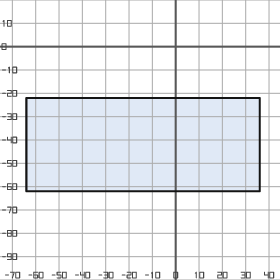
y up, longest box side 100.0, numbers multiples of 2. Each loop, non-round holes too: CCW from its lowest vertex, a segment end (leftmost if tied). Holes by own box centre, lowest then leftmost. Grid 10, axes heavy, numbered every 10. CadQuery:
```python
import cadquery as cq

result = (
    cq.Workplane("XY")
    .moveTo(-64.0, -62.0)
    .lineTo(36.0, -62.0)
    .lineTo(36.0, -22.0)
    .lineTo(-64.0, -22.0)
    .close()
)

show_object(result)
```